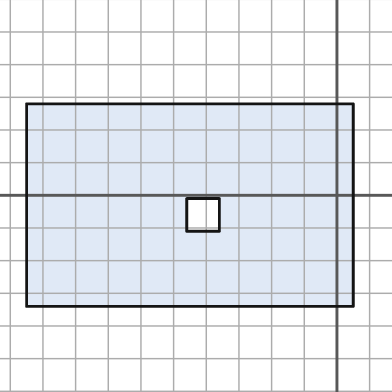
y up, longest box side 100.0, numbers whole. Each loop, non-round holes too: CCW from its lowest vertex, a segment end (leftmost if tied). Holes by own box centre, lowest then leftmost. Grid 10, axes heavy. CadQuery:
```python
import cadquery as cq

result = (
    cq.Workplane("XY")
    .moveTo(-95.0, -34.0)
    .lineTo(5.0, -34.0)
    .lineTo(5.0, 28.0)
    .lineTo(-95.0, 28.0)
    .close()
    .moveTo(-46.0, -11.0)
    .lineTo(-36.0, -11.0)
    .lineTo(-36.0, -1.0)
    .lineTo(-46.0, -1.0)
    .close()
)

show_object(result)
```